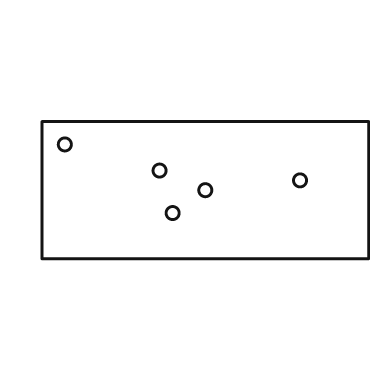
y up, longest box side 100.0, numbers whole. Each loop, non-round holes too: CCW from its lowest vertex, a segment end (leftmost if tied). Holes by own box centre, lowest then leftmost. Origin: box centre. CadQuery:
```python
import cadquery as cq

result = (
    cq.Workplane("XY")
    .moveTo(-50.0, -21.0)
    .lineTo(50.0, -21.0)
    .lineTo(50.0, 21.0)
    .lineTo(-50.0, 21.0)
    .close()
    .moveTo(-10.0, -7.0)
    .circle(2.0)
    .moveTo(0.0, 0.0)
    .circle(2.0)
    .moveTo(29.0, 3.0)
    .circle(2.0)
    .moveTo(-14.0, 6.0)
    .circle(2.0)
    .moveTo(-43.0, 14.0)
    .circle(2.0)
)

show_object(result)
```